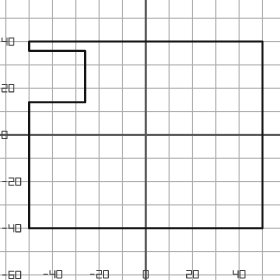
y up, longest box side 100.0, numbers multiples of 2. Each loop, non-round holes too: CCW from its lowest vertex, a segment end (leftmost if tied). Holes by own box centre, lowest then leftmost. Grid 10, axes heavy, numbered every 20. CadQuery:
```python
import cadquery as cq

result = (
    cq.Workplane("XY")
    .moveTo(-50.0, -40.0)
    .lineTo(50.0, -40.0)
    .lineTo(50.0, 40.0)
    .lineTo(-50.0, 40.0)
    .lineTo(-50.0, 36.0)
    .lineTo(-26.0, 36.0)
    .lineTo(-26.0, 14.0)
    .lineTo(-50.0, 14.0)
    .close()
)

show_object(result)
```